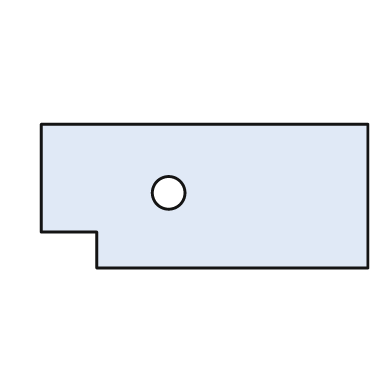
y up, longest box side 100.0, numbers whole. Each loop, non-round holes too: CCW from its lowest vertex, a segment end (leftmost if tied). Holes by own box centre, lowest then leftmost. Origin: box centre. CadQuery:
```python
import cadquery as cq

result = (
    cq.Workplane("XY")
    .moveTo(-33.0, -22.0)
    .lineTo(50.0, -22.0)
    .lineTo(50.0, 22.0)
    .lineTo(-50.0, 22.0)
    .lineTo(-50.0, -11.0)
    .lineTo(-33.0, -11.0)
    .close()
    .moveTo(-11.0, 1.0)
    .circle(5.0)
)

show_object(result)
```